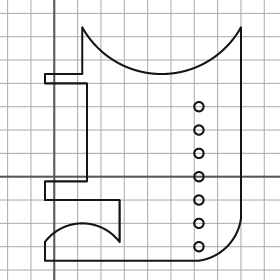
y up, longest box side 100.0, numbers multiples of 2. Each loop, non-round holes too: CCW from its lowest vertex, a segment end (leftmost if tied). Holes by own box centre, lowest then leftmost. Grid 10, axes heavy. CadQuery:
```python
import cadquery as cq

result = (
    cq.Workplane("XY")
    .moveTo(-4.0, -36.0)
    .lineTo(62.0, -36.0)
    .threePointArc((74.0, -30.0), (80.0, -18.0))
    .lineTo(80.0, 64.0)
    .threePointArc((46.0, 44.0), (12.0, 64.0))
    .lineTo(12.0, 44.0)
    .lineTo(-4.0, 44.0)
    .lineTo(-4.0, 40.0)
    .lineTo(14.0, 40.0)
    .lineTo(14.0, -2.0)
    .lineTo(-4.0, -2.0)
    .lineTo(-4.0, -10.0)
    .lineTo(28.0, -10.0)
    .lineTo(28.0, -28.0)
    .threePointArc((12.0, -20.0), (-4.0, -28.0))
    .close()
    .moveTo(62.0, -30.0)
    .circle(2.0)
    .moveTo(62.0, -20.0)
    .circle(2.0)
    .moveTo(62.0, -10.0)
    .circle(2.0)
    .moveTo(62.0, 0.0)
    .circle(2.0)
    .moveTo(62.0, 10.0)
    .circle(2.0)
    .moveTo(62.0, 20.0)
    .circle(2.0)
    .moveTo(62.0, 30.0)
    .circle(2.0)
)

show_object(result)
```